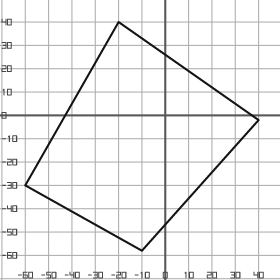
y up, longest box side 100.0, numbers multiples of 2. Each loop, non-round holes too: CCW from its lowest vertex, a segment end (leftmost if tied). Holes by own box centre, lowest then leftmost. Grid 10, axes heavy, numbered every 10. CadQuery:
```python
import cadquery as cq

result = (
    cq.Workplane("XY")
    .moveTo(-10.0, -58.0)
    .lineTo(40.0, -2.0)
    .lineTo(-20.0, 40.0)
    .lineTo(-60.0, -30.0)
    .close()
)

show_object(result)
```